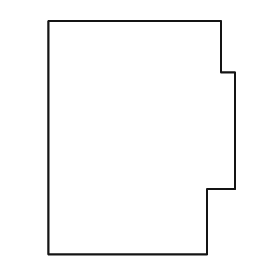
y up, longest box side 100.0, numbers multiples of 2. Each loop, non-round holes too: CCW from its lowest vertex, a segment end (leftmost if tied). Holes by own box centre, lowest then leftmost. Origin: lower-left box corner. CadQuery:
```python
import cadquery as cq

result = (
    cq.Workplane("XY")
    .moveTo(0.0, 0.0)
    .lineTo(68.0, 0.0)
    .lineTo(68.0, 28.0)
    .lineTo(80.0, 28.0)
    .lineTo(80.0, 78.0)
    .lineTo(74.0, 78.0)
    .lineTo(74.0, 100.0)
    .lineTo(0.0, 100.0)
    .close()
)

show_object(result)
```